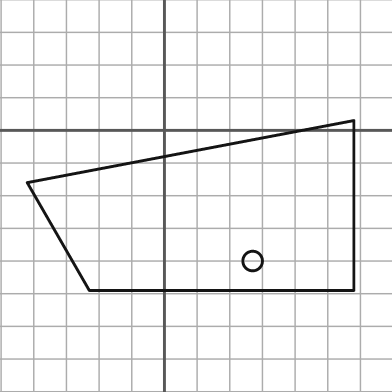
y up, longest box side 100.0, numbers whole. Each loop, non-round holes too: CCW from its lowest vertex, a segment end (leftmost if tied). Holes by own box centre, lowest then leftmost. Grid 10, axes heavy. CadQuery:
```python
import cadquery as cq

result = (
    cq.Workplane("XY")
    .moveTo(-23.0, -49.0)
    .lineTo(58.0, -49.0)
    .lineTo(58.0, 3.0)
    .lineTo(-42.0, -16.0)
    .close()
    .moveTo(27.0, -40.0)
    .circle(3.0)
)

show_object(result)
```